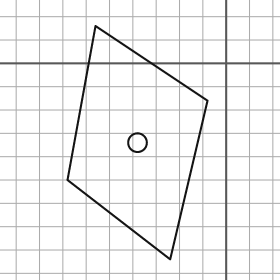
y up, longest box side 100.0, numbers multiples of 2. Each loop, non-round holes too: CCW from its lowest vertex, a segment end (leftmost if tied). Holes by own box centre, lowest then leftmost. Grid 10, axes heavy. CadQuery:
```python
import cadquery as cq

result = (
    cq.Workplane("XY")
    .moveTo(-24.0, -84.0)
    .lineTo(-8.0, -16.0)
    .lineTo(-56.0, 16.0)
    .lineTo(-68.0, -50.0)
    .close()
    .moveTo(-38.0, -34.0)
    .circle(4.0)
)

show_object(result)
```